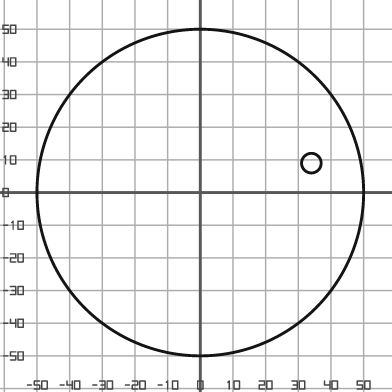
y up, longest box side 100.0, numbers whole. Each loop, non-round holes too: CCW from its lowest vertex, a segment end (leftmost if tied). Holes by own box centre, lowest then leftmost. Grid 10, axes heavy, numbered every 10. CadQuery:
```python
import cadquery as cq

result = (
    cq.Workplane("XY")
    .moveTo(0.0, 0.0)
    .circle(50.0)
    .moveTo(34.0, 9.0)
    .circle(3.0)
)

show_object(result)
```